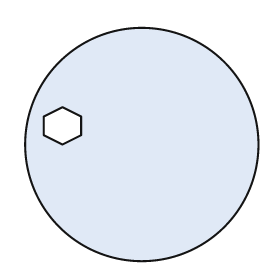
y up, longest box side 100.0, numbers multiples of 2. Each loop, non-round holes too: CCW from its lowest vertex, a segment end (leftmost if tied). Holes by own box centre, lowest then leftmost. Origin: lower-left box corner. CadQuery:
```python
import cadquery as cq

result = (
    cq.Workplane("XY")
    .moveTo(50.0, 50.0)
    .circle(50.0)
    .moveTo(16.0, 50.0)
    .lineTo(24.0, 54.0)
    .lineTo(24.0, 62.0)
    .lineTo(16.0, 66.0)
    .lineTo(8.0, 62.0)
    .lineTo(8.0, 54.0)
    .close()
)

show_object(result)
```